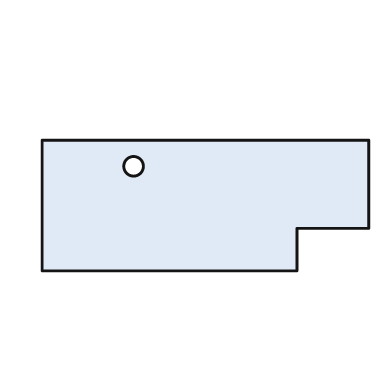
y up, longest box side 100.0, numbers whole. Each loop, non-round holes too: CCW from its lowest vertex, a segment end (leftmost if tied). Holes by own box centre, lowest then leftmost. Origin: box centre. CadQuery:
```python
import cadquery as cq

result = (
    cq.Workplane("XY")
    .moveTo(-50.0, -20.0)
    .lineTo(28.0, -20.0)
    .lineTo(28.0, -7.0)
    .lineTo(50.0, -7.0)
    .lineTo(50.0, 20.0)
    .lineTo(-50.0, 20.0)
    .close()
    .moveTo(-22.0, 12.0)
    .circle(3.0)
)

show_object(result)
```